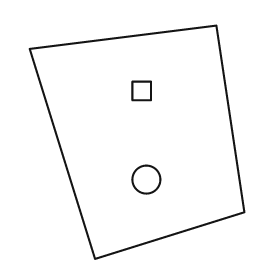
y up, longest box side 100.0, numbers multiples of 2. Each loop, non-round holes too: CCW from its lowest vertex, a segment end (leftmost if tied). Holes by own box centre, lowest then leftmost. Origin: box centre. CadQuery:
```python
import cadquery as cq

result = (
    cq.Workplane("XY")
    .moveTo(-18.0, -50.0)
    .lineTo(46.0, -30.0)
    .lineTo(34.0, 50.0)
    .lineTo(-46.0, 40.0)
    .close()
    .moveTo(4.0, -16.0)
    .circle(6.0)
    .moveTo(-2.0, 18.0)
    .lineTo(6.0, 18.0)
    .lineTo(6.0, 26.0)
    .lineTo(-2.0, 26.0)
    .close()
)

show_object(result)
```